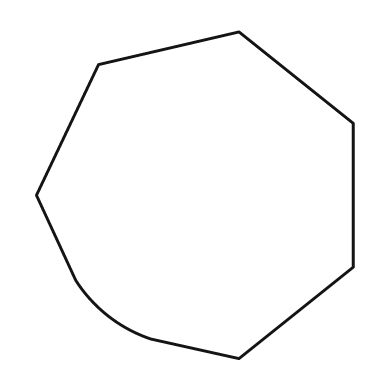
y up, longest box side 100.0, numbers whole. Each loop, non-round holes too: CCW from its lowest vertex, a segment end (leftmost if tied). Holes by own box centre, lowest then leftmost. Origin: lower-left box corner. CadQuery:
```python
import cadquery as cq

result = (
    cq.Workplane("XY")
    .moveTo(62.0, 0.0)
    .lineTo(97.0, 28.0)
    .lineTo(97.0, 72.0)
    .lineTo(62.0, 100.0)
    .lineTo(19.0, 90.0)
    .lineTo(0.0, 50.0)
    .lineTo(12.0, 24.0)
    .threePointArc((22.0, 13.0), (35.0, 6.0))
    .close()
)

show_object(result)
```